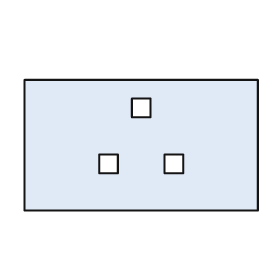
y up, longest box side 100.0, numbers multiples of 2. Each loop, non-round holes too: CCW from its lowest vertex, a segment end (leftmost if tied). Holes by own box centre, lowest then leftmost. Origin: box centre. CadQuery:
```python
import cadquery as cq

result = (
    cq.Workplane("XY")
    .moveTo(-50.0, -28.0)
    .lineTo(50.0, -28.0)
    .lineTo(50.0, 28.0)
    .lineTo(-50.0, 28.0)
    .close()
    .moveTo(-18.0, -12.0)
    .lineTo(-10.0, -12.0)
    .lineTo(-10.0, -4.0)
    .lineTo(-18.0, -4.0)
    .close()
    .moveTo(10.0, -12.0)
    .lineTo(18.0, -12.0)
    .lineTo(18.0, -4.0)
    .lineTo(10.0, -4.0)
    .close()
    .moveTo(-4.0, 12.0)
    .lineTo(4.0, 12.0)
    .lineTo(4.0, 20.0)
    .lineTo(-4.0, 20.0)
    .close()
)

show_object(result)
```